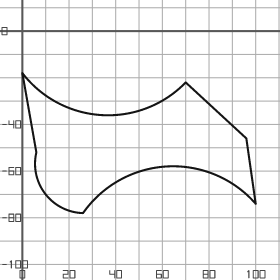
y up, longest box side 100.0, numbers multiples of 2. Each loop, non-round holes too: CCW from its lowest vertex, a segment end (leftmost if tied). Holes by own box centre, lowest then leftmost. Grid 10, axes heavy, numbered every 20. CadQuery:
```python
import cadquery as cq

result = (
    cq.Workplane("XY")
    .moveTo(26.0, -78.0)
    .threePointArc((62.0, -58.0), (100.0, -74.0))
    .lineTo(96.0, -46.0)
    .lineTo(70.0, -22.0)
    .threePointArc((34.0, -36.0), (0.0, -18.0))
    .lineTo(6.0, -52.0)
    .threePointArc((10.0, -70.0), (26.0, -78.0))
    .close()
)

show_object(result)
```